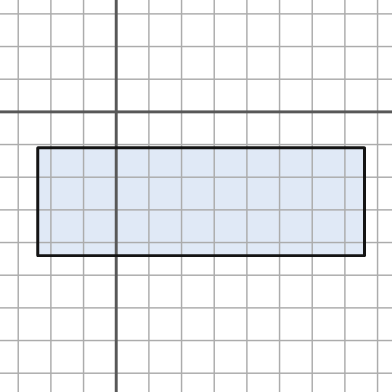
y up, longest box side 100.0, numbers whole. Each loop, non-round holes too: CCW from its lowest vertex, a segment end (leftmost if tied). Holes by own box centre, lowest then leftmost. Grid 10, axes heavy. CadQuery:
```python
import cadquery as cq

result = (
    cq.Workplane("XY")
    .moveTo(-24.0, -44.0)
    .lineTo(76.0, -44.0)
    .lineTo(76.0, -11.0)
    .lineTo(-24.0, -11.0)
    .close()
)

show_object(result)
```